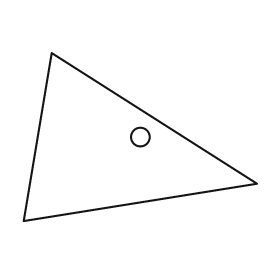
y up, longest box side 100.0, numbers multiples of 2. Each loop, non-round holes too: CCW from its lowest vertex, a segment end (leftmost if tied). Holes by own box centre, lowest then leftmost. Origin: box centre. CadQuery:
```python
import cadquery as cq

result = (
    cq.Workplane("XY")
    .moveTo(-50.0, -36.0)
    .lineTo(50.0, -20.0)
    .lineTo(-38.0, 36.0)
    .close()
    .moveTo(0.0, 0.0)
    .circle(4.0)
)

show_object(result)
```